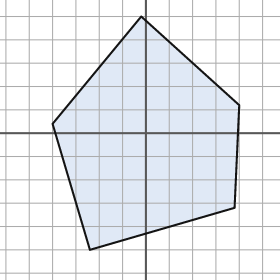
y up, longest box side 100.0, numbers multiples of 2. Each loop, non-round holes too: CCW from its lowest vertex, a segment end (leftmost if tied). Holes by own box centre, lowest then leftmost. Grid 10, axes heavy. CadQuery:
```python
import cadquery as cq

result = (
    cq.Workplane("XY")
    .moveTo(-24.0, -50.0)
    .lineTo(38.0, -32.0)
    .lineTo(40.0, 12.0)
    .lineTo(-2.0, 50.0)
    .lineTo(-40.0, 4.0)
    .close()
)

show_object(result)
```